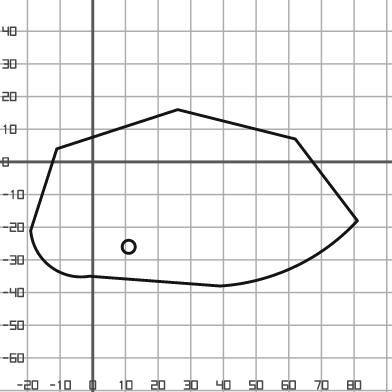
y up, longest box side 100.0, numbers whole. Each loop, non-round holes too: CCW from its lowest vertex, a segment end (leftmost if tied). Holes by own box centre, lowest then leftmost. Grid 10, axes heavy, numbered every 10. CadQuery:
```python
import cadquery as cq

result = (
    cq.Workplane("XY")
    .moveTo(39.0, -38.0)
    .threePointArc((62.0, -32.0), (81.0, -18.0))
    .lineTo(62.0, 7.0)
    .lineTo(26.0, 16.0)
    .lineTo(-11.0, 4.0)
    .lineTo(-19.0, -21.0)
    .threePointArc((-13.0, -32.0), (-1.0, -35.0))
    .close()
    .moveTo(11.0, -26.0)
    .circle(2.0)
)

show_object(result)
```